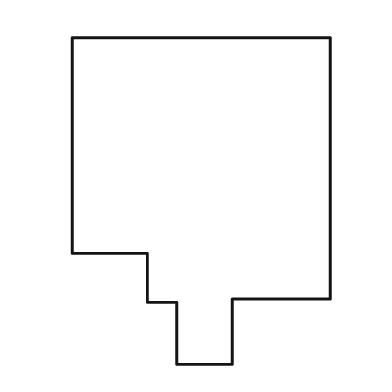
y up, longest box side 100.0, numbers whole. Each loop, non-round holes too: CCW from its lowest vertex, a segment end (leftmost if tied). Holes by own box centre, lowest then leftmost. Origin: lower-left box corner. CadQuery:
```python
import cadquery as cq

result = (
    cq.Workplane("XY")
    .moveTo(32.0, 0.0)
    .lineTo(49.0, 0.0)
    .lineTo(49.0, 20.0)
    .lineTo(79.0, 20.0)
    .lineTo(79.0, 100.0)
    .lineTo(0.0, 100.0)
    .lineTo(0.0, 34.0)
    .lineTo(23.0, 34.0)
    .lineTo(23.0, 19.0)
    .lineTo(32.0, 19.0)
    .close()
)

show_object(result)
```